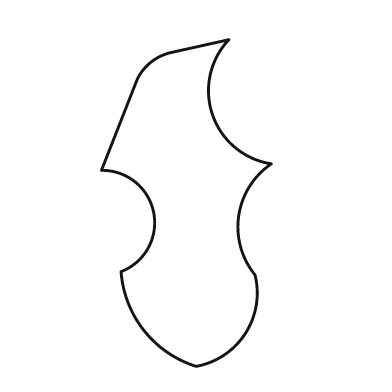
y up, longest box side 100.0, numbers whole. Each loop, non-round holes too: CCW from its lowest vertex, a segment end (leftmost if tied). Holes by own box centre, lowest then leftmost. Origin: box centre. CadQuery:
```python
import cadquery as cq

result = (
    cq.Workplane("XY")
    .moveTo(3.0, -50.0)
    .threePointArc((18.0, -40.0), (21.0, -22.0))
    .threePointArc((16.0, -4.0), (26.0, 12.0))
    .threePointArc((8.0, 27.0), (13.0, 50.0))
    .lineTo(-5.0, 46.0)
    .threePointArc((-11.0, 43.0), (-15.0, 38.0))
    .lineTo(-26.0, 10.0)
    .threePointArc((-10.0, -3.0), (-20.0, -21.0))
    .threePointArc((-13.0, -39.0), (3.0, -50.0))
    .close()
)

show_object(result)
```